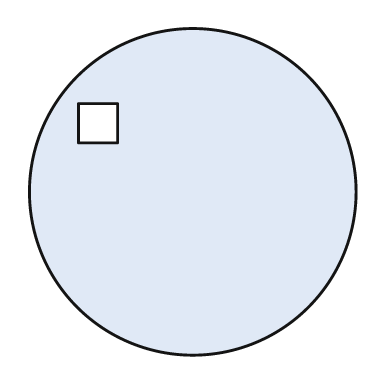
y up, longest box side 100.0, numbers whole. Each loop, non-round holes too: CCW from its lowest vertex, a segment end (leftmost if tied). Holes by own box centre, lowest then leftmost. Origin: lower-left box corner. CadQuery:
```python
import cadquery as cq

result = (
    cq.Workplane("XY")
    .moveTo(50.0, 50.0)
    .circle(50.0)
    .moveTo(15.0, 65.0)
    .lineTo(27.0, 65.0)
    .lineTo(27.0, 77.0)
    .lineTo(15.0, 77.0)
    .close()
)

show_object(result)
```